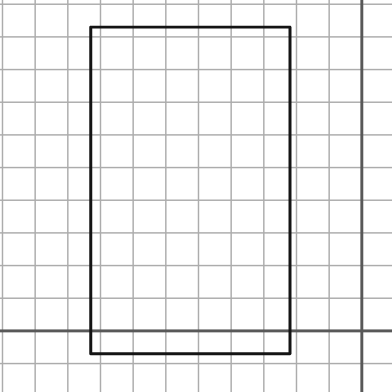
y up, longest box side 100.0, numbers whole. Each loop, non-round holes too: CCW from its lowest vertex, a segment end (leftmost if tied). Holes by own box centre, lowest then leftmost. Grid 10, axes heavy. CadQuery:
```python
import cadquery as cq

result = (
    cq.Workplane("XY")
    .moveTo(-83.0, -7.0)
    .lineTo(-22.0, -7.0)
    .lineTo(-22.0, 93.0)
    .lineTo(-83.0, 93.0)
    .close()
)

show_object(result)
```